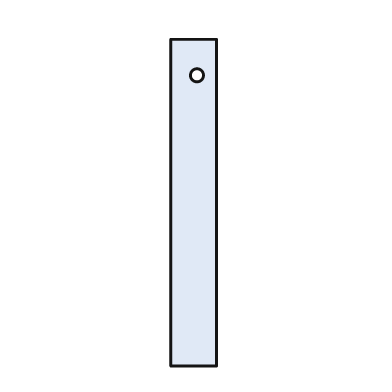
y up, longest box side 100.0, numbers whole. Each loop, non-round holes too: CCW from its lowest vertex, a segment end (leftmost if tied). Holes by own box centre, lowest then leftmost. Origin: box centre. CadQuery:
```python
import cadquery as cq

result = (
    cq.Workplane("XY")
    .moveTo(-7.0, -50.0)
    .lineTo(7.0, -50.0)
    .lineTo(7.0, 50.0)
    .lineTo(-7.0, 50.0)
    .close()
    .moveTo(1.0, 39.0)
    .circle(2.0)
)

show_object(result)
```